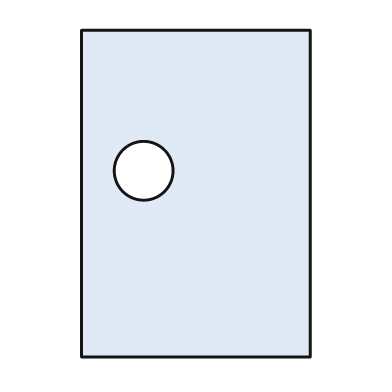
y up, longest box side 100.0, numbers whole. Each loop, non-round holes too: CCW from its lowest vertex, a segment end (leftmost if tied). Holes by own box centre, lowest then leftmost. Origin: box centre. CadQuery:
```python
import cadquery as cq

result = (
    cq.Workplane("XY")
    .moveTo(-35.0, -50.0)
    .lineTo(35.0, -50.0)
    .lineTo(35.0, 50.0)
    .lineTo(-35.0, 50.0)
    .close()
    .moveTo(-16.0, 7.0)
    .circle(9.0)
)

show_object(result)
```